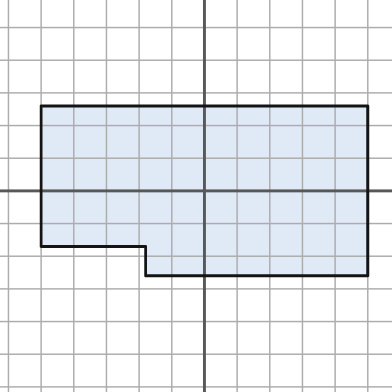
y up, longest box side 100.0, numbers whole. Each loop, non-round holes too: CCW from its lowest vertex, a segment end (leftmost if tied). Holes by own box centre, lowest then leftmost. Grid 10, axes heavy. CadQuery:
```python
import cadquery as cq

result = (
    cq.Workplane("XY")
    .moveTo(-18.0, -26.0)
    .lineTo(50.0, -26.0)
    .lineTo(50.0, 26.0)
    .lineTo(-50.0, 26.0)
    .lineTo(-50.0, -17.0)
    .lineTo(-18.0, -17.0)
    .close()
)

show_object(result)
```